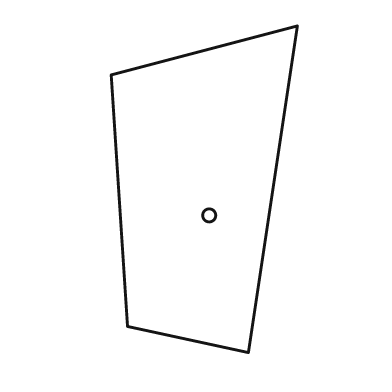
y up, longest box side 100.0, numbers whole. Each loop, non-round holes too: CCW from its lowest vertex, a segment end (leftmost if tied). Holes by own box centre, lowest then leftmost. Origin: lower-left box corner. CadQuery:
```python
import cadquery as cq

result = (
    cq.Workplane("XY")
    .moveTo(42.0, 0.0)
    .lineTo(57.0, 100.0)
    .lineTo(0.0, 85.0)
    .lineTo(5.0, 8.0)
    .close()
    .moveTo(30.0, 42.0)
    .circle(2.0)
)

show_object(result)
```